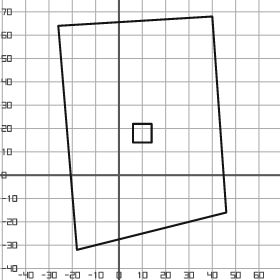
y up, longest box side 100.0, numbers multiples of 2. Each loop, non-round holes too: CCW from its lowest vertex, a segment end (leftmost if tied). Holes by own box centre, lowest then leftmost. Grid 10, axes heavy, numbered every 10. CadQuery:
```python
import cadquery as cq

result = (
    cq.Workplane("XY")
    .moveTo(-18.0, -32.0)
    .lineTo(46.0, -16.0)
    .lineTo(40.0, 68.0)
    .lineTo(-26.0, 64.0)
    .close()
    .moveTo(6.0, 14.0)
    .lineTo(14.0, 14.0)
    .lineTo(14.0, 22.0)
    .lineTo(6.0, 22.0)
    .close()
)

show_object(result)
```